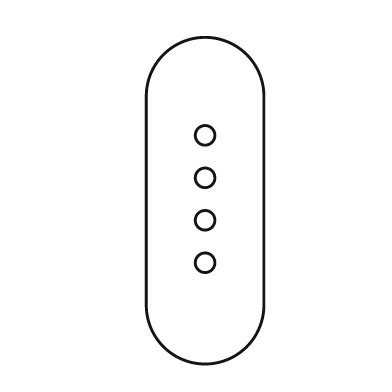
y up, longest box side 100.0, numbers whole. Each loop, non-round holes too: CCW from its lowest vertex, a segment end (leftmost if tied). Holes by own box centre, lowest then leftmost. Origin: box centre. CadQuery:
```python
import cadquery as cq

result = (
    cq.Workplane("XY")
    .moveTo(-18.0, -32.0)
    .threePointArc((0.0, -50.0), (18.0, -32.0))
    .lineTo(18.0, 32.0)
    .threePointArc((0.0, 50.0), (-18.0, 32.0))
    .close()
    .moveTo(0.0, -19.0)
    .circle(3.0)
    .moveTo(0.0, -6.0)
    .circle(3.0)
    .moveTo(0.0, 7.0)
    .circle(3.0)
    .moveTo(0.0, 20.0)
    .circle(3.0)
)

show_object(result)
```